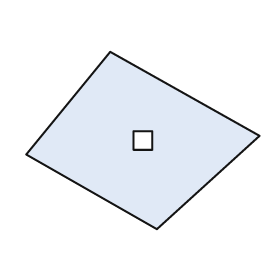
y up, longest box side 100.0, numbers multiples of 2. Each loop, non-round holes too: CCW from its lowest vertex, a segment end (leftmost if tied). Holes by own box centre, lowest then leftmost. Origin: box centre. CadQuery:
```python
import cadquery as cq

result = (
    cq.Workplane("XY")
    .moveTo(6.0, -38.0)
    .lineTo(50.0, 2.0)
    .lineTo(-14.0, 38.0)
    .lineTo(-50.0, -6.0)
    .close()
    .moveTo(-4.0, -4.0)
    .lineTo(4.0, -4.0)
    .lineTo(4.0, 4.0)
    .lineTo(-4.0, 4.0)
    .close()
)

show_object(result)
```